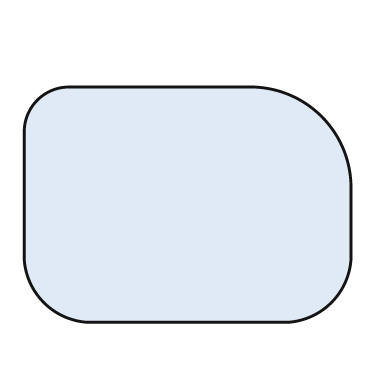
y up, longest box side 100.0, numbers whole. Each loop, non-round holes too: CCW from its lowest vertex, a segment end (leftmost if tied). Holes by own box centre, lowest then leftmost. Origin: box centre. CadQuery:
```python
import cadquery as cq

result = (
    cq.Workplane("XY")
    .moveTo(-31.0, -36.0)
    .lineTo(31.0, -36.0)
    .threePointArc((44.0, -30.0), (50.0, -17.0))
    .lineTo(50.0, 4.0)
    .threePointArc((41.0, 27.0), (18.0, 36.0))
    .lineTo(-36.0, 36.0)
    .threePointArc((-46.0, 32.0), (-50.0, 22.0))
    .lineTo(-50.0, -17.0)
    .threePointArc((-44.0, -30.0), (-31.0, -36.0))
    .close()
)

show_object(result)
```